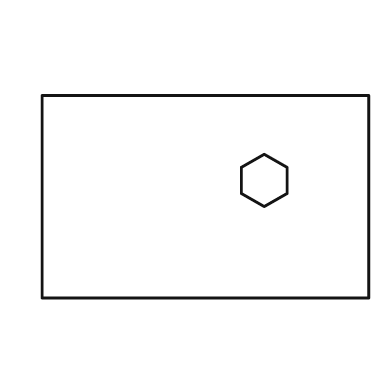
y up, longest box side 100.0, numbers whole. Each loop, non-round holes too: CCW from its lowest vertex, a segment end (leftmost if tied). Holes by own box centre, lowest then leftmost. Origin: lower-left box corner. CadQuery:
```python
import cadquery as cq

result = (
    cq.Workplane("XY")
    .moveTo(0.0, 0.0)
    .lineTo(100.0, 0.0)
    .lineTo(100.0, 62.0)
    .lineTo(0.0, 62.0)
    .close()
    .moveTo(68.0, 28.0)
    .lineTo(75.0, 32.0)
    .lineTo(75.0, 40.0)
    .lineTo(68.0, 44.0)
    .lineTo(61.0, 40.0)
    .lineTo(61.0, 32.0)
    .close()
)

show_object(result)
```